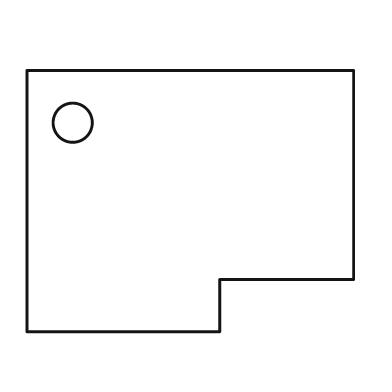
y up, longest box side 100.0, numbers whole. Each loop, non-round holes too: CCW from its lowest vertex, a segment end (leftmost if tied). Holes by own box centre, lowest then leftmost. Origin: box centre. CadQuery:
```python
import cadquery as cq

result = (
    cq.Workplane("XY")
    .moveTo(-50.0, -40.0)
    .lineTo(9.0, -40.0)
    .lineTo(9.0, -24.0)
    .lineTo(50.0, -24.0)
    .lineTo(50.0, 40.0)
    .lineTo(-50.0, 40.0)
    .close()
    .moveTo(-36.0, 24.0)
    .circle(6.0)
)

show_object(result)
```